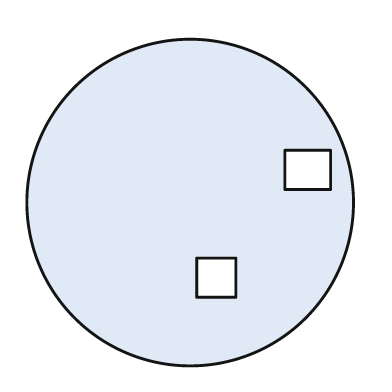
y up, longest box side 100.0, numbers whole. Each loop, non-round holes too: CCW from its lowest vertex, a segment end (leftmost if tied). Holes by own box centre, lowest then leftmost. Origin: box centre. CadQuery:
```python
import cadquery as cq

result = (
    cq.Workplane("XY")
    .moveTo(0.0, 0.0)
    .circle(50.0)
    .moveTo(2.0, -29.0)
    .lineTo(14.0, -29.0)
    .lineTo(14.0, -17.0)
    .lineTo(2.0, -17.0)
    .close()
    .moveTo(29.0, 4.0)
    .lineTo(43.0, 4.0)
    .lineTo(43.0, 16.0)
    .lineTo(29.0, 16.0)
    .close()
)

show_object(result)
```